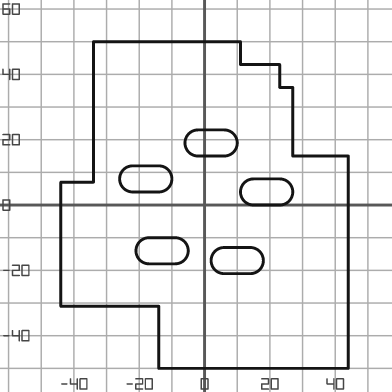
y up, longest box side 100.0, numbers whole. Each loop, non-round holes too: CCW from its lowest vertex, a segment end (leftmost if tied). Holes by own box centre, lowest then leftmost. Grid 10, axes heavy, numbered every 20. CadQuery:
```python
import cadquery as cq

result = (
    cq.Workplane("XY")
    .moveTo(-14.0, -50.0)
    .lineTo(44.0, -50.0)
    .lineTo(44.0, 15.0)
    .lineTo(27.0, 15.0)
    .lineTo(27.0, 36.0)
    .lineTo(23.0, 36.0)
    .lineTo(23.0, 43.0)
    .lineTo(11.0, 43.0)
    .lineTo(11.0, 50.0)
    .lineTo(-34.0, 50.0)
    .lineTo(-34.0, 7.0)
    .lineTo(-44.0, 7.0)
    .lineTo(-44.0, -31.0)
    .lineTo(-14.0, -31.0)
    .close()
    .moveTo(6.0, -21.0)
    .lineTo(14.0, -21.0)
    .threePointArc((18.0, -17.0), (14.0, -13.0))
    .lineTo(6.0, -13.0)
    .threePointArc((2.0, -17.0), (6.0, -21.0))
    .close()
    .moveTo(-17.0, -18.0)
    .lineTo(-9.0, -18.0)
    .threePointArc((-5.0, -14.0), (-9.0, -10.0))
    .lineTo(-17.0, -10.0)
    .threePointArc((-21.0, -14.0), (-17.0, -18.0))
    .close()
    .moveTo(15.0, 0.0)
    .lineTo(23.0, 0.0)
    .threePointArc((27.0, 4.0), (23.0, 8.0))
    .lineTo(15.0, 8.0)
    .threePointArc((11.0, 4.0), (15.0, 0.0))
    .close()
    .moveTo(-22.0, 4.0)
    .lineTo(-14.0, 4.0)
    .threePointArc((-10.0, 8.0), (-14.0, 12.0))
    .lineTo(-22.0, 12.0)
    .threePointArc((-26.0, 8.0), (-22.0, 4.0))
    .close()
    .moveTo(-2.0, 15.0)
    .lineTo(6.0, 15.0)
    .threePointArc((10.0, 19.0), (6.0, 23.0))
    .lineTo(-2.0, 23.0)
    .threePointArc((-6.0, 19.0), (-2.0, 15.0))
    .close()
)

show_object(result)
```